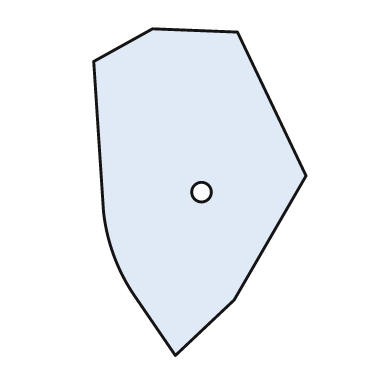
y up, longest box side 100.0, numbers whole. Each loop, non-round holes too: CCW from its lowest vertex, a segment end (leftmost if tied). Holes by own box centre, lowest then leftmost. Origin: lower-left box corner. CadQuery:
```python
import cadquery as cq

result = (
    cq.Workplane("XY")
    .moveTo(25.0, 0.0)
    .lineTo(43.0, 17.0)
    .lineTo(65.0, 55.0)
    .lineTo(44.0, 99.0)
    .lineTo(18.0, 100.0)
    .lineTo(0.0, 90.0)
    .lineTo(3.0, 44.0)
    .threePointArc((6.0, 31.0), (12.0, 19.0))
    .close()
    .moveTo(33.0, 50.0)
    .circle(3.0)
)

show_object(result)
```